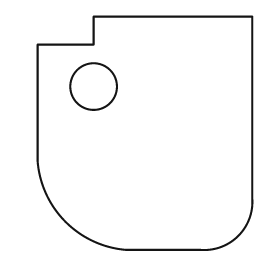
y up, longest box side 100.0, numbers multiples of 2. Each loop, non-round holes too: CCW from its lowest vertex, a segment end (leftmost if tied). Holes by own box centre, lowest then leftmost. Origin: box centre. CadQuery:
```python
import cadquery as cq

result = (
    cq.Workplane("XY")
    .moveTo(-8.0, -50.0)
    .lineTo(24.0, -50.0)
    .threePointArc((40.0, -44.0), (46.0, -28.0))
    .lineTo(46.0, 50.0)
    .lineTo(-22.0, 50.0)
    .lineTo(-22.0, 38.0)
    .lineTo(-46.0, 38.0)
    .lineTo(-46.0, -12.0)
    .threePointArc((-34.0, -38.0), (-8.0, -50.0))
    .close()
    .moveTo(-22.0, 20.0)
    .circle(10.0)
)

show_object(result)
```